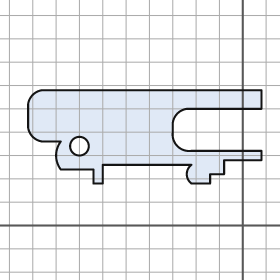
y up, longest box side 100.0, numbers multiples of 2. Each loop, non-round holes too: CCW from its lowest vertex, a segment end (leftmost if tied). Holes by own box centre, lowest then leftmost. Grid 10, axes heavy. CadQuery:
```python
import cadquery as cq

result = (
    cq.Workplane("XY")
    .moveTo(-64.0, 18.0)
    .lineTo(-60.0, 18.0)
    .lineTo(-60.0, 26.0)
    .lineTo(-22.0, 26.0)
    .threePointArc((-24.0, 22.0), (-22.0, 18.0))
    .lineTo(-14.0, 18.0)
    .lineTo(-14.0, 22.0)
    .lineTo(-8.0, 22.0)
    .lineTo(-8.0, 28.0)
    .lineTo(8.0, 28.0)
    .lineTo(8.0, 32.0)
    .lineTo(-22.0, 32.0)
    .threePointArc((-28.0, 34.0), (-30.0, 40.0))
    .lineTo(-30.0, 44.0)
    .threePointArc((-28.0, 48.0), (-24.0, 50.0))
    .lineTo(8.0, 50.0)
    .lineTo(8.0, 58.0)
    .lineTo(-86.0, 58.0)
    .threePointArc((-90.0, 56.0), (-92.0, 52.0))
    .lineTo(-92.0, 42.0)
    .threePointArc((-90.0, 38.0), (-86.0, 36.0))
    .lineTo(-78.0, 36.0)
    .threePointArc((-80.0, 30.0), (-78.0, 24.0))
    .lineTo(-64.0, 24.0)
    .close()
    .moveTo(-70.0, 34.0)
    .circle(4.0)
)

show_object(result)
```